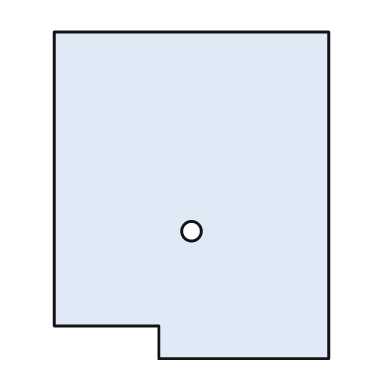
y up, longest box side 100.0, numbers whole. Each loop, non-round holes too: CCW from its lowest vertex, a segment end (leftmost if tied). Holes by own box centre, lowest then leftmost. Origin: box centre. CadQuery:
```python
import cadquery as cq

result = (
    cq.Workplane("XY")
    .moveTo(-10.0, -50.0)
    .lineTo(42.0, -50.0)
    .lineTo(42.0, 50.0)
    .lineTo(-42.0, 50.0)
    .lineTo(-42.0, -40.0)
    .lineTo(-10.0, -40.0)
    .close()
    .moveTo(0.0, -11.0)
    .circle(3.0)
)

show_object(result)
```